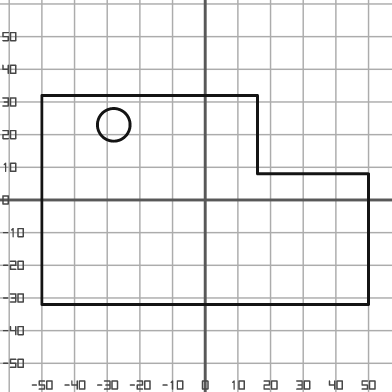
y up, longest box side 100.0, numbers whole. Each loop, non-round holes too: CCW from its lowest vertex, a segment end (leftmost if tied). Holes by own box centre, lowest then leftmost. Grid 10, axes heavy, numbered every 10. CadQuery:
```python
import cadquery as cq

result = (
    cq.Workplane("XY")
    .moveTo(-50.0, -32.0)
    .lineTo(50.0, -32.0)
    .lineTo(50.0, 8.0)
    .lineTo(16.0, 8.0)
    .lineTo(16.0, 32.0)
    .lineTo(-50.0, 32.0)
    .close()
    .moveTo(-28.0, 23.0)
    .circle(5.0)
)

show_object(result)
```